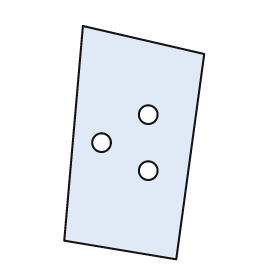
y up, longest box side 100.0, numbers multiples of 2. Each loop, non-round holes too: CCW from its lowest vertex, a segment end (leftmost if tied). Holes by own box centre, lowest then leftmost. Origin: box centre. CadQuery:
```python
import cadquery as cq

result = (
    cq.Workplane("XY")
    .moveTo(18.0, -50.0)
    .lineTo(30.0, 38.0)
    .lineTo(-22.0, 50.0)
    .lineTo(-30.0, -42.0)
    .close()
    .moveTo(6.0, -12.0)
    .circle(4.0)
    .moveTo(-14.0, 0.0)
    .circle(4.0)
    .moveTo(6.0, 12.0)
    .circle(4.0)
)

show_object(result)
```